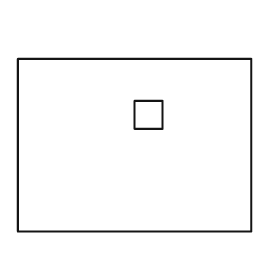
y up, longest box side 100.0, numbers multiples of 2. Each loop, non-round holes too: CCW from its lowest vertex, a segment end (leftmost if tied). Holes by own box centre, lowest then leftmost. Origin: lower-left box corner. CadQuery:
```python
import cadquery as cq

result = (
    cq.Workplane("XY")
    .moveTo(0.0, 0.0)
    .lineTo(100.0, 0.0)
    .lineTo(100.0, 74.0)
    .lineTo(0.0, 74.0)
    .close()
    .moveTo(50.0, 44.0)
    .lineTo(62.0, 44.0)
    .lineTo(62.0, 56.0)
    .lineTo(50.0, 56.0)
    .close()
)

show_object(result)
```